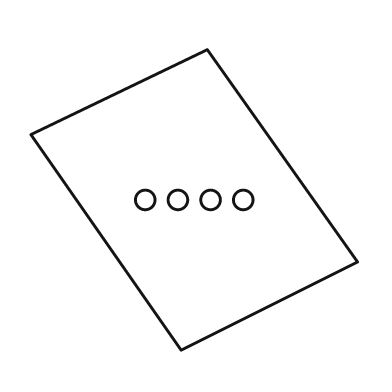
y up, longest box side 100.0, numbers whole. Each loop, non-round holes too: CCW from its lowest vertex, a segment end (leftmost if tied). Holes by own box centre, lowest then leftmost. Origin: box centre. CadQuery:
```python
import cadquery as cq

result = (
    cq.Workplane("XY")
    .moveTo(-4.0, -46.0)
    .lineTo(50.0, -19.0)
    .lineTo(4.0, 46.0)
    .lineTo(-50.0, 20.0)
    .close()
    .moveTo(-15.0, 0.0)
    .circle(3.0)
    .moveTo(-5.0, 0.0)
    .circle(3.0)
    .moveTo(5.0, 0.0)
    .circle(3.0)
    .moveTo(15.0, 0.0)
    .circle(3.0)
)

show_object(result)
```